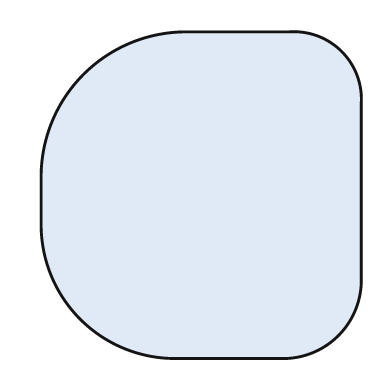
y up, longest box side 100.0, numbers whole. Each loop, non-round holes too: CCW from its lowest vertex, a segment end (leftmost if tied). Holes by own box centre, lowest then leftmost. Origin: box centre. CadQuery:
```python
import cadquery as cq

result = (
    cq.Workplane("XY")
    .moveTo(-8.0, -50.0)
    .lineTo(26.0, -50.0)
    .threePointArc((42.0, -43.0), (49.0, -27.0))
    .lineTo(49.0, 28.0)
    .threePointArc((43.0, 44.0), (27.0, 50.0))
    .lineTo(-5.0, 50.0)
    .threePointArc((-36.0, 37.0), (-49.0, 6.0))
    .lineTo(-49.0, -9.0)
    .threePointArc((-37.0, -38.0), (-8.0, -50.0))
    .close()
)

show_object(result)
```